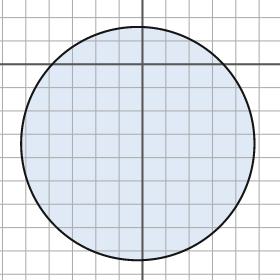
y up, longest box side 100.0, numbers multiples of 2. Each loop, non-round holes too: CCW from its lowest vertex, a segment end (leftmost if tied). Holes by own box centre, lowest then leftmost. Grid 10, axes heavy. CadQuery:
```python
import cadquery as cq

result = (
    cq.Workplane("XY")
    .moveTo(-2.0, -34.0)
    .circle(50.0)
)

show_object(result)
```